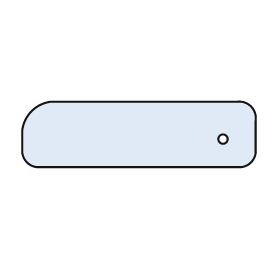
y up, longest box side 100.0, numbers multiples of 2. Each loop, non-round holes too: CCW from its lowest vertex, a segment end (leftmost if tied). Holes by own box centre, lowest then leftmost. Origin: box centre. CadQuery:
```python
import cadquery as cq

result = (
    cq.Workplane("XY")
    .moveTo(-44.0, -14.0)
    .lineTo(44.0, -14.0)
    .threePointArc((48.0, -12.0), (50.0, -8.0))
    .lineTo(50.0, 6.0)
    .threePointArc((48.0, 12.0), (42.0, 14.0))
    .lineTo(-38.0, 14.0)
    .threePointArc((-46.0, 10.0), (-50.0, 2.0))
    .lineTo(-50.0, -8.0)
    .threePointArc((-48.0, -12.0), (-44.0, -14.0))
    .close()
    .moveTo(36.0, -2.0)
    .circle(2.0)
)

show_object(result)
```